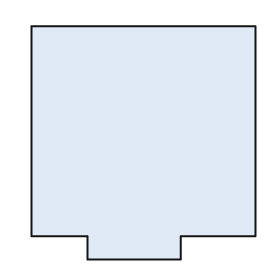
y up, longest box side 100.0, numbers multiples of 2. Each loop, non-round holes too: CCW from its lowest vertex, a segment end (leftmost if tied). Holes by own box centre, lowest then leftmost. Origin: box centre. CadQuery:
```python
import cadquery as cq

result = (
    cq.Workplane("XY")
    .moveTo(-24.0, -50.0)
    .lineTo(16.0, -50.0)
    .lineTo(16.0, -40.0)
    .lineTo(48.0, -40.0)
    .lineTo(48.0, 50.0)
    .lineTo(-48.0, 50.0)
    .lineTo(-48.0, -40.0)
    .lineTo(-24.0, -40.0)
    .close()
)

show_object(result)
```